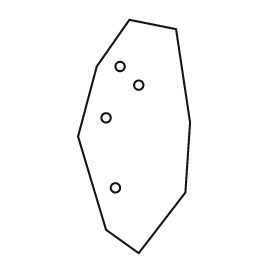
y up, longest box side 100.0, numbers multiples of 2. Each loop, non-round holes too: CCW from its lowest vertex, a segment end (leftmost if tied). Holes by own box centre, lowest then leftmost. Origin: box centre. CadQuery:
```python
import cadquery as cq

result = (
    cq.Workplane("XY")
    .moveTo(2.0, -50.0)
    .lineTo(22.0, -24.0)
    .lineTo(24.0, 6.0)
    .lineTo(18.0, 46.0)
    .lineTo(-2.0, 50.0)
    .lineTo(-16.0, 30.0)
    .lineTo(-24.0, 0.0)
    .lineTo(-12.0, -40.0)
    .close()
    .moveTo(-8.0, -22.0)
    .circle(2.0)
    .moveTo(-12.0, 8.0)
    .circle(2.0)
    .moveTo(2.0, 22.0)
    .circle(2.0)
    .moveTo(-6.0, 30.0)
    .circle(2.0)
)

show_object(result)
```